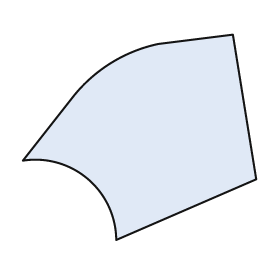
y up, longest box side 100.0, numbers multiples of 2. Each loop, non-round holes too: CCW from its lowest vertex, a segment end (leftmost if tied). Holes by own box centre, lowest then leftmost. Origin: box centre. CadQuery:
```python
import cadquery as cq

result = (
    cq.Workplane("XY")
    .moveTo(-10.0, -44.0)
    .lineTo(50.0, -18.0)
    .lineTo(40.0, 44.0)
    .lineTo(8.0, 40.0)
    .threePointArc((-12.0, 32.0), (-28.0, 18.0))
    .lineTo(-50.0, -10.0)
    .threePointArc((-22.0, -18.0), (-10.0, -44.0))
    .close()
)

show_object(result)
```